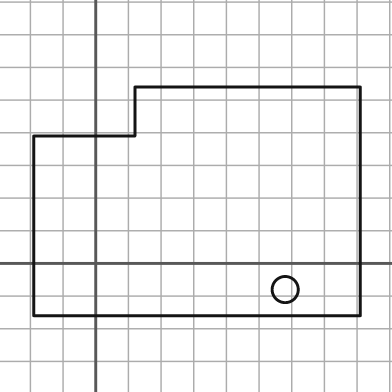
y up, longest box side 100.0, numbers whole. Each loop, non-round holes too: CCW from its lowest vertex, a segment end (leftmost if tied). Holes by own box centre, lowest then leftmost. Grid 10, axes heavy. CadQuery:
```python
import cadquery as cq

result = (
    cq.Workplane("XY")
    .moveTo(-19.0, -16.0)
    .lineTo(81.0, -16.0)
    .lineTo(81.0, 54.0)
    .lineTo(12.0, 54.0)
    .lineTo(12.0, 39.0)
    .lineTo(-19.0, 39.0)
    .close()
    .moveTo(58.0, -8.0)
    .circle(4.0)
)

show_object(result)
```